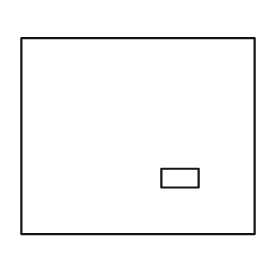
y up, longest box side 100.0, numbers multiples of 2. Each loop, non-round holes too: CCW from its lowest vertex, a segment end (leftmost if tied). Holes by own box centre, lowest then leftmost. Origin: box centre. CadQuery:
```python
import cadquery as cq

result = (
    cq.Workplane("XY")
    .moveTo(-50.0, -42.0)
    .lineTo(50.0, -42.0)
    .lineTo(50.0, 42.0)
    .lineTo(-50.0, 42.0)
    .close()
    .moveTo(10.0, -22.0)
    .lineTo(26.0, -22.0)
    .lineTo(26.0, -14.0)
    .lineTo(10.0, -14.0)
    .close()
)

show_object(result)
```